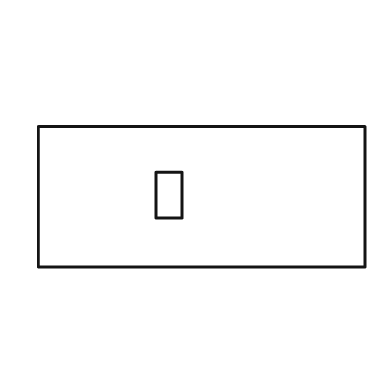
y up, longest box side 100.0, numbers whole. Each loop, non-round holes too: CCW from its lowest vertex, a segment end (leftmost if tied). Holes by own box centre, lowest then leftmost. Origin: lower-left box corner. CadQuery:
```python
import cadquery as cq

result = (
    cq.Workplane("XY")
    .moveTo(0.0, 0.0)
    .lineTo(100.0, 0.0)
    .lineTo(100.0, 43.0)
    .lineTo(0.0, 43.0)
    .close()
    .moveTo(36.0, 15.0)
    .lineTo(44.0, 15.0)
    .lineTo(44.0, 29.0)
    .lineTo(36.0, 29.0)
    .close()
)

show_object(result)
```